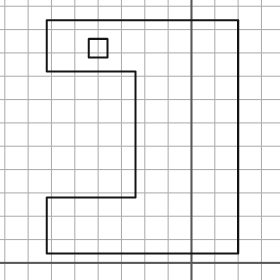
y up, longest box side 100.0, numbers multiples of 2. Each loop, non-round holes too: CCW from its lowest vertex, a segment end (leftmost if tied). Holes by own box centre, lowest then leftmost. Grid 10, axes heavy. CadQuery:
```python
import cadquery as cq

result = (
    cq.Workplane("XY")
    .moveTo(-62.0, 4.0)
    .lineTo(20.0, 4.0)
    .lineTo(20.0, 104.0)
    .lineTo(-62.0, 104.0)
    .lineTo(-62.0, 82.0)
    .lineTo(-24.0, 82.0)
    .lineTo(-24.0, 28.0)
    .lineTo(-62.0, 28.0)
    .close()
    .moveTo(-44.0, 88.0)
    .lineTo(-36.0, 88.0)
    .lineTo(-36.0, 96.0)
    .lineTo(-44.0, 96.0)
    .close()
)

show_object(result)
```